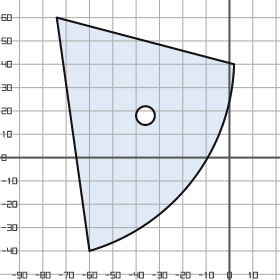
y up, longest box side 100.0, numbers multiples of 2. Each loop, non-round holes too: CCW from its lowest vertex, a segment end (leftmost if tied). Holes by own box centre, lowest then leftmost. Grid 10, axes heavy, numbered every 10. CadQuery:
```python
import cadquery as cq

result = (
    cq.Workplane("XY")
    .moveTo(-60.0, -40.0)
    .threePointArc((-16.0, -10.0), (2.0, 40.0))
    .lineTo(-74.0, 60.0)
    .close()
    .moveTo(-36.0, 18.0)
    .circle(4.0)
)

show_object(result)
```